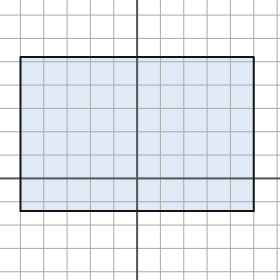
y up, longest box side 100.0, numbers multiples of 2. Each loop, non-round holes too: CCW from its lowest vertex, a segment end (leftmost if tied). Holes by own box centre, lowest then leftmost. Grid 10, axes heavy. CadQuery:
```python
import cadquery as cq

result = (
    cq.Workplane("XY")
    .moveTo(-50.0, -14.0)
    .lineTo(50.0, -14.0)
    .lineTo(50.0, 52.0)
    .lineTo(-50.0, 52.0)
    .close()
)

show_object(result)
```